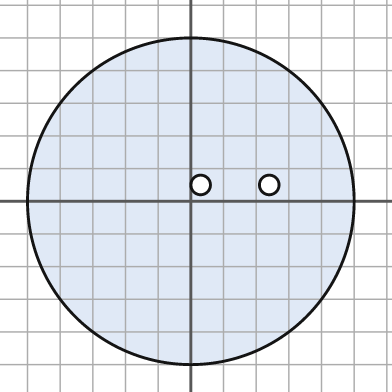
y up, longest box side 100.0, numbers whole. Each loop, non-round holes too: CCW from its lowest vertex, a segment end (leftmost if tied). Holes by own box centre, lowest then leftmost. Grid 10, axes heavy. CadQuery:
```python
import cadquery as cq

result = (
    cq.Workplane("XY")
    .moveTo(0.0, 0.0)
    .circle(50.0)
    .moveTo(3.0, 5.0)
    .circle(3.0)
    .moveTo(24.0, 5.0)
    .circle(3.0)
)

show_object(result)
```